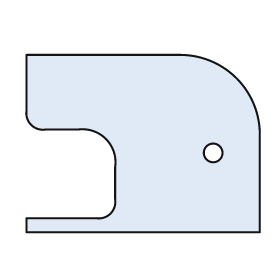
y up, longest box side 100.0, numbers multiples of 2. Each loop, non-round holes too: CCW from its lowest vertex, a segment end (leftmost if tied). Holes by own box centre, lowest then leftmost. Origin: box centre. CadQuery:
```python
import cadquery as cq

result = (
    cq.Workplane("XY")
    .moveTo(-50.0, -38.0)
    .lineTo(50.0, -38.0)
    .lineTo(50.0, 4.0)
    .threePointArc((40.0, 28.0), (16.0, 38.0))
    .lineTo(-50.0, 38.0)
    .lineTo(-50.0, 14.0)
    .threePointArc((-48.0, 8.0), (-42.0, 6.0))
    .lineTo(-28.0, 6.0)
    .threePointArc((-16.0, 2.0), (-12.0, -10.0))
    .lineTo(-12.0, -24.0)
    .threePointArc((-14.0, -30.0), (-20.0, -32.0))
    .lineTo(-50.0, -32.0)
    .close()
    .moveTo(30.0, -4.0)
    .circle(4.0)
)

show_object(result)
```